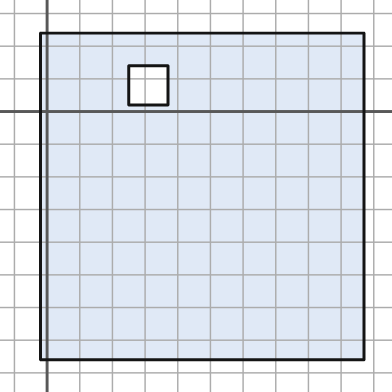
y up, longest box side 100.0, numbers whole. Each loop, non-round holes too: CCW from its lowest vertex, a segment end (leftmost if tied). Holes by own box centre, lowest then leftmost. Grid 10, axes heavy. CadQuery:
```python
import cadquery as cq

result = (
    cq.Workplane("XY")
    .moveTo(-2.0, -76.0)
    .lineTo(97.0, -76.0)
    .lineTo(97.0, 24.0)
    .lineTo(-2.0, 24.0)
    .close()
    .moveTo(25.0, 2.0)
    .lineTo(37.0, 2.0)
    .lineTo(37.0, 14.0)
    .lineTo(25.0, 14.0)
    .close()
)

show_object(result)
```